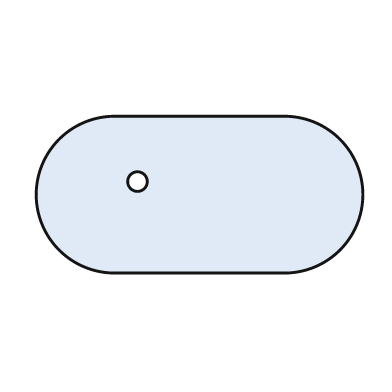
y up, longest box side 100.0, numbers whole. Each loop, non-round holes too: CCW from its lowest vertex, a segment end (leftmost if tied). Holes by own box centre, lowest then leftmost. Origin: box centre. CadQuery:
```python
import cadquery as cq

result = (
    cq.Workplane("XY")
    .moveTo(-26.0, -24.0)
    .lineTo(26.0, -24.0)
    .threePointArc((50.0, 0.0), (26.0, 24.0))
    .lineTo(-26.0, 24.0)
    .threePointArc((-50.0, 0.0), (-26.0, -24.0))
    .close()
    .moveTo(-19.0, 4.0)
    .circle(3.0)
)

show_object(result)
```